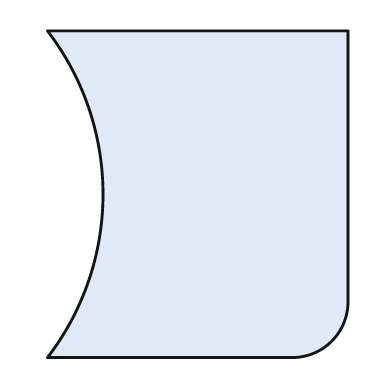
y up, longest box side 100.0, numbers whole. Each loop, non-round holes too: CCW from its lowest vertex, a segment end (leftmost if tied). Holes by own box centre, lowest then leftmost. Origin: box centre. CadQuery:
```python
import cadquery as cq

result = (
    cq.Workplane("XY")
    .moveTo(-46.0, -50.0)
    .lineTo(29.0, -50.0)
    .threePointArc((41.0, -45.0), (46.0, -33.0))
    .lineTo(46.0, 50.0)
    .lineTo(-46.0, 50.0)
    .threePointArc((-29.0, 0.0), (-46.0, -50.0))
    .close()
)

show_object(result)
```